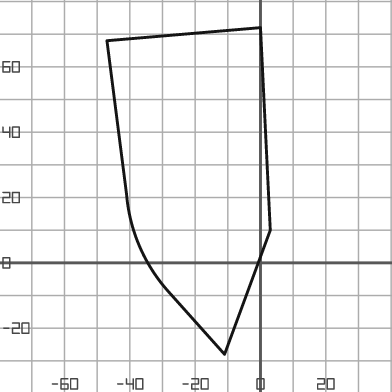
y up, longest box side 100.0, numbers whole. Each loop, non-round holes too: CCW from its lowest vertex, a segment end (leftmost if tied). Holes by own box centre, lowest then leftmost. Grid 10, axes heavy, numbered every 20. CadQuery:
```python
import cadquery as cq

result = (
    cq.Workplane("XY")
    .moveTo(-11.0, -28.0)
    .lineTo(3.0, 10.0)
    .lineTo(0.0, 72.0)
    .lineTo(-47.0, 68.0)
    .lineTo(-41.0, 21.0)
    .threePointArc((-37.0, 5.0), (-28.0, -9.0))
    .close()
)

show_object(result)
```